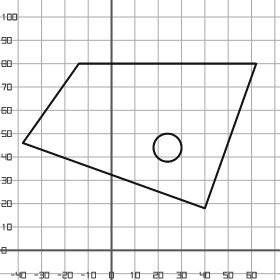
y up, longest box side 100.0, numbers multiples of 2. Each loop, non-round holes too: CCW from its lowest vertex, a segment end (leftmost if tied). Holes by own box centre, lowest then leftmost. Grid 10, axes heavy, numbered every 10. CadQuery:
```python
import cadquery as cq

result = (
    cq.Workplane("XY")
    .moveTo(40.0, 18.0)
    .lineTo(62.0, 80.0)
    .lineTo(-14.0, 80.0)
    .lineTo(-38.0, 46.0)
    .close()
    .moveTo(24.0, 44.0)
    .circle(6.0)
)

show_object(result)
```